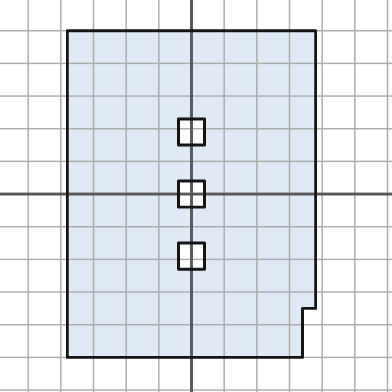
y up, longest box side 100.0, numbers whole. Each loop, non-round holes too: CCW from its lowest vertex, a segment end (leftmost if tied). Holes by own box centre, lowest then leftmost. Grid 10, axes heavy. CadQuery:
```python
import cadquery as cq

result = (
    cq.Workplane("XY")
    .moveTo(-38.0, -50.0)
    .lineTo(34.0, -50.0)
    .lineTo(34.0, -35.0)
    .lineTo(38.0, -35.0)
    .lineTo(38.0, 50.0)
    .lineTo(-38.0, 50.0)
    .close()
    .moveTo(-4.0, -23.0)
    .lineTo(4.0, -23.0)
    .lineTo(4.0, -15.0)
    .lineTo(-4.0, -15.0)
    .close()
    .moveTo(-4.0, -4.0)
    .lineTo(4.0, -4.0)
    .lineTo(4.0, 4.0)
    .lineTo(-4.0, 4.0)
    .close()
    .moveTo(-4.0, 15.0)
    .lineTo(4.0, 15.0)
    .lineTo(4.0, 23.0)
    .lineTo(-4.0, 23.0)
    .close()
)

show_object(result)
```